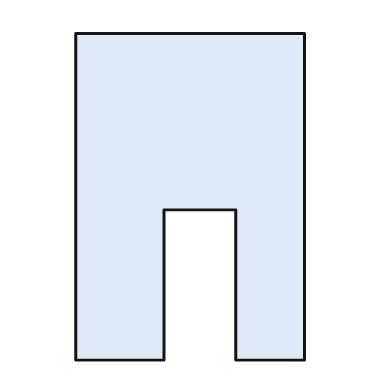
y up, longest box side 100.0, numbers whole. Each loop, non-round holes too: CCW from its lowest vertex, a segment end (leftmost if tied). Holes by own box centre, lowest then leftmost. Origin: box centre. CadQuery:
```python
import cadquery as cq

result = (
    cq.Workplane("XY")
    .moveTo(-35.0, -50.0)
    .lineTo(-8.0, -50.0)
    .lineTo(-8.0, -4.0)
    .lineTo(14.0, -4.0)
    .lineTo(14.0, -50.0)
    .lineTo(35.0, -50.0)
    .lineTo(35.0, 50.0)
    .lineTo(-35.0, 50.0)
    .close()
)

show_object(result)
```